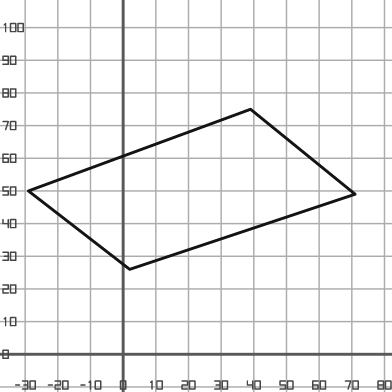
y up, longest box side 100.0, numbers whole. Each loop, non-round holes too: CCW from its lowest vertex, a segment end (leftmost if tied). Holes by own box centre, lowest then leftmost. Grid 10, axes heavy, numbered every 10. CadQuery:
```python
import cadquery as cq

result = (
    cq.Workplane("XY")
    .moveTo(2.0, 26.0)
    .lineTo(71.0, 49.0)
    .lineTo(39.0, 75.0)
    .lineTo(-29.0, 50.0)
    .close()
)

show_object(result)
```